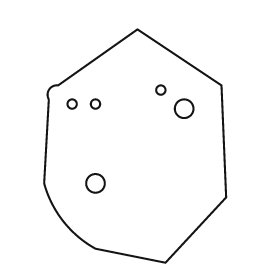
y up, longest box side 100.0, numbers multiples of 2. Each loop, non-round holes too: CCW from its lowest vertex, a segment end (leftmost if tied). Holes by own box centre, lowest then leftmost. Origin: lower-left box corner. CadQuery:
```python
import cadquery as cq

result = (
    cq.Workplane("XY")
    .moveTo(52.0, 0.0)
    .lineTo(78.0, 28.0)
    .lineTo(76.0, 76.0)
    .lineTo(40.0, 100.0)
    .lineTo(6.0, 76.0)
    .threePointArc((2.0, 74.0), (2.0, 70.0))
    .lineTo(0.0, 34.0)
    .threePointArc((8.0, 18.0), (22.0, 6.0))
    .close()
    .moveTo(22.0, 34.0)
    .circle(4.0)
    .moveTo(60.0, 66.0)
    .circle(4.0)
    .moveTo(12.0, 68.0)
    .circle(2.0)
    .moveTo(22.0, 68.0)
    .circle(2.0)
    .moveTo(50.0, 74.0)
    .circle(2.0)
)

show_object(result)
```